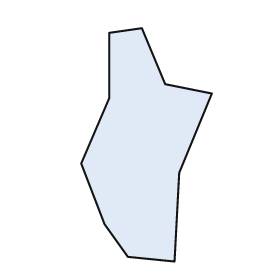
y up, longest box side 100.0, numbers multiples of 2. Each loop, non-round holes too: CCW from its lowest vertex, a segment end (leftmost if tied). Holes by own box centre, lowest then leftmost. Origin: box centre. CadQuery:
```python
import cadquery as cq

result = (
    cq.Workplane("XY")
    .moveTo(12.0, -50.0)
    .lineTo(14.0, -12.0)
    .lineTo(28.0, 22.0)
    .lineTo(8.0, 26.0)
    .lineTo(-2.0, 50.0)
    .lineTo(-16.0, 48.0)
    .lineTo(-16.0, 20.0)
    .lineTo(-28.0, -8.0)
    .lineTo(-18.0, -34.0)
    .lineTo(-8.0, -48.0)
    .close()
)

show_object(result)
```